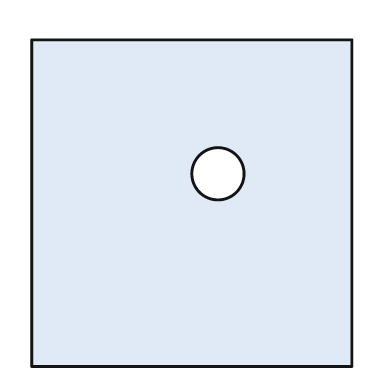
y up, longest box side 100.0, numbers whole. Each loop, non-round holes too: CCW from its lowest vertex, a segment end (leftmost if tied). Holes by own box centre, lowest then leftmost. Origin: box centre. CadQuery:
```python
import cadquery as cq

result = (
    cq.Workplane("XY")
    .moveTo(-49.0, -50.0)
    .lineTo(49.0, -50.0)
    .lineTo(49.0, 50.0)
    .lineTo(-49.0, 50.0)
    .close()
    .moveTo(8.0, 9.0)
    .circle(8.0)
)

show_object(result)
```